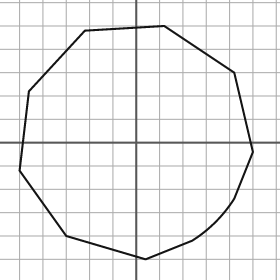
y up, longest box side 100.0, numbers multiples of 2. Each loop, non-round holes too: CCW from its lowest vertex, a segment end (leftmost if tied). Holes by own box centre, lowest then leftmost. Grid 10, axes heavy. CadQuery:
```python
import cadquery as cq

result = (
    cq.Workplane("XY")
    .moveTo(4.0, -50.0)
    .lineTo(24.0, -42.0)
    .threePointArc((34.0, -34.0), (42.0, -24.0))
    .lineTo(50.0, -4.0)
    .lineTo(42.0, 30.0)
    .lineTo(12.0, 50.0)
    .lineTo(-22.0, 48.0)
    .lineTo(-46.0, 22.0)
    .lineTo(-50.0, -12.0)
    .lineTo(-30.0, -40.0)
    .close()
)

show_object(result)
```